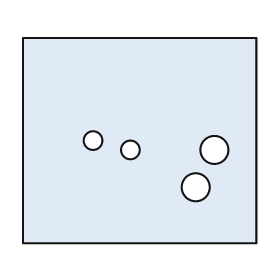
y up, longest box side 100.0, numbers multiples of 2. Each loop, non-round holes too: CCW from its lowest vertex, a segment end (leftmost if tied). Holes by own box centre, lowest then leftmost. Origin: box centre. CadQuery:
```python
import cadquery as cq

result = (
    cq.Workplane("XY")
    .moveTo(-50.0, -44.0)
    .lineTo(50.0, -44.0)
    .lineTo(50.0, 44.0)
    .lineTo(-50.0, 44.0)
    .close()
    .moveTo(24.0, -20.0)
    .circle(6.0)
    .moveTo(-4.0, -4.0)
    .circle(4.0)
    .moveTo(32.0, -4.0)
    .circle(6.0)
    .moveTo(-20.0, 0.0)
    .circle(4.0)
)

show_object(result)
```